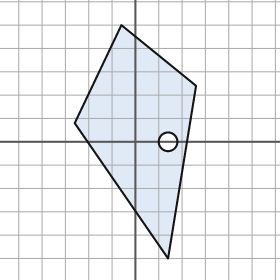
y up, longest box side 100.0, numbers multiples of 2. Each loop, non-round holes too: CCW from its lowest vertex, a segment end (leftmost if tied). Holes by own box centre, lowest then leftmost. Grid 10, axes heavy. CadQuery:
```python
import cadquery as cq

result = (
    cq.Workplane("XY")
    .moveTo(14.0, -50.0)
    .lineTo(26.0, 24.0)
    .lineTo(-6.0, 50.0)
    .lineTo(-26.0, 8.0)
    .close()
    .moveTo(14.0, 0.0)
    .circle(4.0)
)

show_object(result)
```